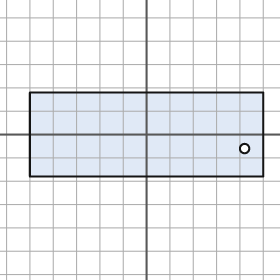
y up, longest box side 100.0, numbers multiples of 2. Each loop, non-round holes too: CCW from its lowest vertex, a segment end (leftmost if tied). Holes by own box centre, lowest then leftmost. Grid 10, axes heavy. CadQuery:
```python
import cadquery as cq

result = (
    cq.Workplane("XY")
    .moveTo(-50.0, -18.0)
    .lineTo(50.0, -18.0)
    .lineTo(50.0, 18.0)
    .lineTo(-50.0, 18.0)
    .close()
    .moveTo(42.0, -6.0)
    .circle(2.0)
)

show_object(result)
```